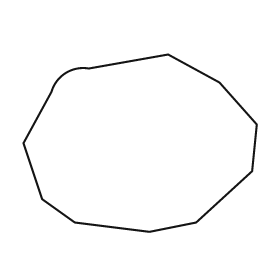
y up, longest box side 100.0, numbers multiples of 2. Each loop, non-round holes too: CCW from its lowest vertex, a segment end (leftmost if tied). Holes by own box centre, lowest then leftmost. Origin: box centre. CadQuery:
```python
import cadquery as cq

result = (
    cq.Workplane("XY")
    .moveTo(4.0, -38.0)
    .lineTo(24.0, -34.0)
    .lineTo(48.0, -12.0)
    .lineTo(50.0, 8.0)
    .lineTo(34.0, 26.0)
    .lineTo(12.0, 38.0)
    .lineTo(-22.0, 32.0)
    .threePointArc((-32.0, 30.0), (-38.0, 22.0))
    .lineTo(-50.0, 0.0)
    .lineTo(-42.0, -24.0)
    .lineTo(-28.0, -34.0)
    .close()
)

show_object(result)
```